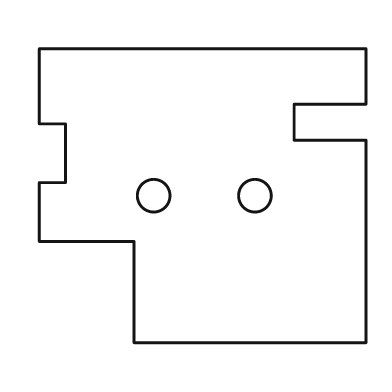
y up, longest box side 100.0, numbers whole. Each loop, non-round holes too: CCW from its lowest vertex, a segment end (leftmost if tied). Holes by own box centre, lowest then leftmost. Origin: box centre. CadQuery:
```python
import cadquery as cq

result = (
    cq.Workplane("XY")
    .moveTo(-21.0, -45.0)
    .lineTo(50.0, -45.0)
    .lineTo(50.0, 17.0)
    .lineTo(28.0, 17.0)
    .lineTo(28.0, 28.0)
    .lineTo(50.0, 28.0)
    .lineTo(50.0, 45.0)
    .lineTo(-50.0, 45.0)
    .lineTo(-50.0, 22.0)
    .lineTo(-42.0, 22.0)
    .lineTo(-42.0, 4.0)
    .lineTo(-50.0, 4.0)
    .lineTo(-50.0, -14.0)
    .lineTo(-21.0, -14.0)
    .close()
    .moveTo(-15.0, 0.0)
    .circle(5.0)
    .moveTo(16.0, 0.0)
    .circle(5.0)
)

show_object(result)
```